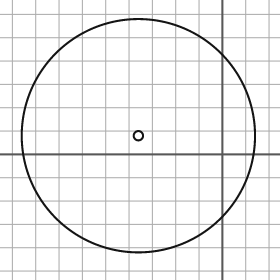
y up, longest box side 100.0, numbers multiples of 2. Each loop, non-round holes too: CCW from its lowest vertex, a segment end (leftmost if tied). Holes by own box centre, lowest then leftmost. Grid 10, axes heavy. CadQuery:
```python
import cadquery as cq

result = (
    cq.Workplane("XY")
    .moveTo(-36.0, 8.0)
    .circle(50.0)
    .moveTo(-36.0, 8.0)
    .circle(2.0)
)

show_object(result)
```